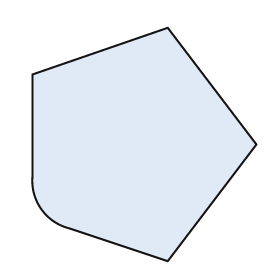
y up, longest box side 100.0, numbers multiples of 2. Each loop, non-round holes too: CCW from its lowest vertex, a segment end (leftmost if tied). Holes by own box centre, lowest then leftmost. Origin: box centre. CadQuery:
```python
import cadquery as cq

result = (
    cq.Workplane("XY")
    .moveTo(10.0, -50.0)
    .lineTo(48.0, 0.0)
    .lineTo(10.0, 50.0)
    .lineTo(-48.0, 30.0)
    .lineTo(-48.0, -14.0)
    .threePointArc((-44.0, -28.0), (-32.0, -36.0))
    .close()
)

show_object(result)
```